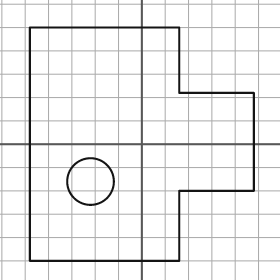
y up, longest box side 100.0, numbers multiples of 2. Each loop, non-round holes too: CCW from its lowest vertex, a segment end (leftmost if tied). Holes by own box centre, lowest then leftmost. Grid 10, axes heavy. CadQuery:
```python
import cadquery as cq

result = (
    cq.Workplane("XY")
    .moveTo(-48.0, -50.0)
    .lineTo(16.0, -50.0)
    .lineTo(16.0, -20.0)
    .lineTo(48.0, -20.0)
    .lineTo(48.0, 22.0)
    .lineTo(16.0, 22.0)
    .lineTo(16.0, 50.0)
    .lineTo(-48.0, 50.0)
    .close()
    .moveTo(-22.0, -16.0)
    .circle(10.0)
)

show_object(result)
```